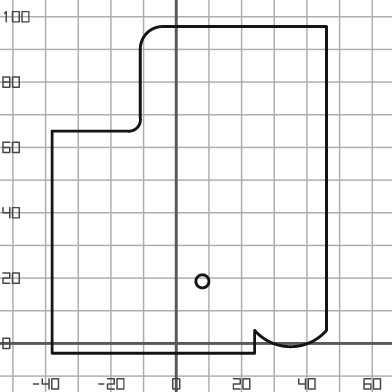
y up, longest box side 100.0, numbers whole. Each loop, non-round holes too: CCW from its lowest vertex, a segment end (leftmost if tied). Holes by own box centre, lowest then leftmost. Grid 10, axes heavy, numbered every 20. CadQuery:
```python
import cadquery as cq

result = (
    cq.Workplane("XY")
    .moveTo(-38.0, -3.0)
    .lineTo(24.0, -3.0)
    .lineTo(24.0, 4.0)
    .threePointArc((35.0, -1.0), (46.0, 4.0))
    .lineTo(46.0, 97.0)
    .lineTo(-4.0, 97.0)
    .threePointArc((-9.0, 95.0), (-11.0, 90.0))
    .lineTo(-11.0, 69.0)
    .threePointArc((-12.0, 66.0), (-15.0, 65.0))
    .lineTo(-38.0, 65.0)
    .close()
    .moveTo(8.0, 19.0)
    .circle(2.0)
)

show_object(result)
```